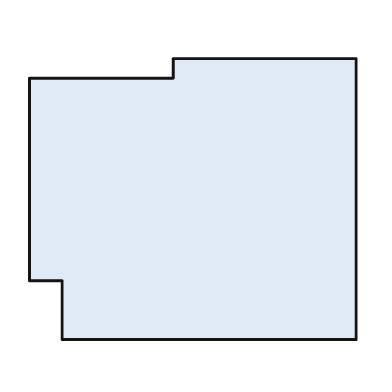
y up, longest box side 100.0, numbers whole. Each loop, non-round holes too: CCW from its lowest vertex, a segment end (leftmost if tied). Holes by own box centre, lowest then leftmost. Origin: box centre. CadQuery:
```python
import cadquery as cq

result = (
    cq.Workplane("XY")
    .moveTo(-40.0, -43.0)
    .lineTo(50.0, -43.0)
    .lineTo(50.0, 43.0)
    .lineTo(-6.0, 43.0)
    .lineTo(-6.0, 37.0)
    .lineTo(-50.0, 37.0)
    .lineTo(-50.0, -25.0)
    .lineTo(-40.0, -25.0)
    .close()
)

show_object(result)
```